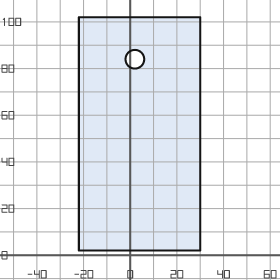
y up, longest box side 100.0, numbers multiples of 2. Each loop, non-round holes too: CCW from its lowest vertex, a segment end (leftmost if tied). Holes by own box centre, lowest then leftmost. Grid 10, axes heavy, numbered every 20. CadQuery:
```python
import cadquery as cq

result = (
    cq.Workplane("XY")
    .moveTo(-22.0, 2.0)
    .lineTo(30.0, 2.0)
    .lineTo(30.0, 102.0)
    .lineTo(-22.0, 102.0)
    .close()
    .moveTo(2.0, 84.0)
    .circle(4.0)
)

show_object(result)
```